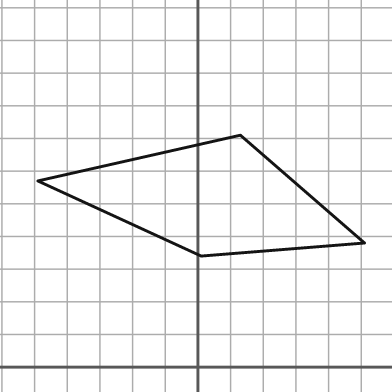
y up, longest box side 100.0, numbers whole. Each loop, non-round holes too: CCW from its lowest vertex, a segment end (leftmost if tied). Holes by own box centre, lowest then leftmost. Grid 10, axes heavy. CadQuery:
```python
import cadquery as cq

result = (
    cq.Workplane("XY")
    .moveTo(1.0, 34.0)
    .lineTo(51.0, 38.0)
    .lineTo(13.0, 71.0)
    .lineTo(-49.0, 57.0)
    .close()
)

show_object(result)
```